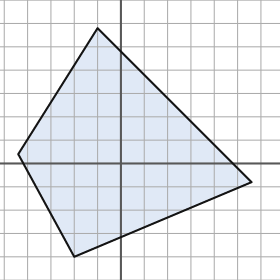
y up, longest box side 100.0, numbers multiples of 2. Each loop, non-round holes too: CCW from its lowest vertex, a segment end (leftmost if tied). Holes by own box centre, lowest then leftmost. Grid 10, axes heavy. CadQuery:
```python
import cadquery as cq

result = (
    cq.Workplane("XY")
    .moveTo(-20.0, -40.0)
    .lineTo(56.0, -8.0)
    .lineTo(-10.0, 58.0)
    .lineTo(-44.0, 4.0)
    .close()
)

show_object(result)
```